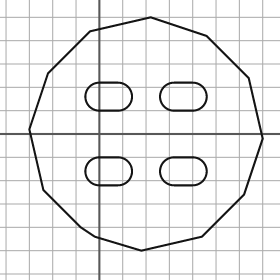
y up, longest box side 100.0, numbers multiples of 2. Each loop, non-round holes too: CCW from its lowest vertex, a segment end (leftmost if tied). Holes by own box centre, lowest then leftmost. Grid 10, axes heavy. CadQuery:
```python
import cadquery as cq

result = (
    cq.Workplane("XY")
    .moveTo(18.0, -50.0)
    .lineTo(44.0, -44.0)
    .lineTo(62.0, -26.0)
    .lineTo(70.0, -2.0)
    .lineTo(64.0, 24.0)
    .lineTo(46.0, 42.0)
    .lineTo(22.0, 50.0)
    .lineTo(-4.0, 44.0)
    .lineTo(-22.0, 26.0)
    .lineTo(-30.0, 2.0)
    .lineTo(-24.0, -24.0)
    .lineTo(-8.0, -40.0)
    .lineTo(-2.0, -44.0)
    .close()
    .moveTo(0.0, -22.0)
    .lineTo(8.0, -22.0)
    .threePointArc((14.0, -16.0), (8.0, -10.0))
    .lineTo(0.0, -10.0)
    .threePointArc((-6.0, -16.0), (0.0, -22.0))
    .close()
    .moveTo(32.0, -22.0)
    .lineTo(40.0, -22.0)
    .threePointArc((46.0, -16.0), (40.0, -10.0))
    .lineTo(32.0, -10.0)
    .threePointArc((26.0, -16.0), (32.0, -22.0))
    .close()
    .moveTo(0.0, 10.0)
    .lineTo(8.0, 10.0)
    .threePointArc((14.0, 16.0), (8.0, 22.0))
    .lineTo(0.0, 22.0)
    .threePointArc((-6.0, 16.0), (0.0, 10.0))
    .close()
    .moveTo(32.0, 10.0)
    .lineTo(40.0, 10.0)
    .threePointArc((46.0, 16.0), (40.0, 22.0))
    .lineTo(32.0, 22.0)
    .threePointArc((26.0, 16.0), (32.0, 10.0))
    .close()
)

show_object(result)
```